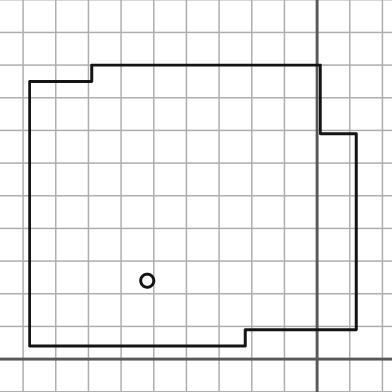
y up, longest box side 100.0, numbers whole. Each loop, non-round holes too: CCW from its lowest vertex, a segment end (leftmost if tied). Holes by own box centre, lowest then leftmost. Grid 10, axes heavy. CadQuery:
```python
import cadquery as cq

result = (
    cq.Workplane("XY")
    .moveTo(-88.0, 4.0)
    .lineTo(-22.0, 4.0)
    .lineTo(-22.0, 9.0)
    .lineTo(12.0, 9.0)
    .lineTo(12.0, 69.0)
    .lineTo(1.0, 69.0)
    .lineTo(1.0, 90.0)
    .lineTo(-69.0, 90.0)
    .lineTo(-69.0, 85.0)
    .lineTo(-88.0, 85.0)
    .close()
    .moveTo(-52.0, 24.0)
    .circle(2.0)
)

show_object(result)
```